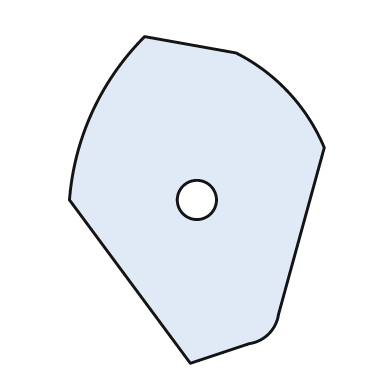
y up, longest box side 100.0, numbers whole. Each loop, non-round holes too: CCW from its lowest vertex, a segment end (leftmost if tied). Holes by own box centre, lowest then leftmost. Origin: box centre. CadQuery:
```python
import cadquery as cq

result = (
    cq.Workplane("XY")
    .moveTo(-2.0, -50.0)
    .lineTo(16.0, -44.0)
    .threePointArc((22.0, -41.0), (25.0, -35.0))
    .lineTo(39.0, 16.0)
    .threePointArc((28.0, 33.0), (12.0, 45.0))
    .lineTo(-16.0, 50.0)
    .threePointArc((-32.0, 27.0), (-39.0, 0.0))
    .close()
    .moveTo(0.0, 0.0)
    .circle(6.0)
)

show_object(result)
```